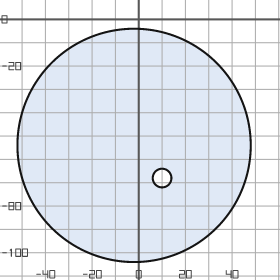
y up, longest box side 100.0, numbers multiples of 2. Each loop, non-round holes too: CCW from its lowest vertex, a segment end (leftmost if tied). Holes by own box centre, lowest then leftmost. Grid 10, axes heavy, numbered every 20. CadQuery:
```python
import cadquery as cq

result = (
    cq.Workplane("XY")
    .moveTo(-2.0, -54.0)
    .circle(50.0)
    .moveTo(10.0, -68.0)
    .circle(4.0)
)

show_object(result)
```